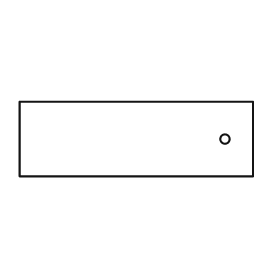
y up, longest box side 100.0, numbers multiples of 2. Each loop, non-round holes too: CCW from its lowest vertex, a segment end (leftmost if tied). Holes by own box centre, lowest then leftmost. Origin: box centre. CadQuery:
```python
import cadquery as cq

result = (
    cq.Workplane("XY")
    .moveTo(-50.0, -16.0)
    .lineTo(50.0, -16.0)
    .lineTo(50.0, 16.0)
    .lineTo(-50.0, 16.0)
    .close()
    .moveTo(38.0, 0.0)
    .circle(2.0)
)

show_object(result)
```